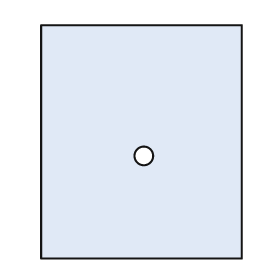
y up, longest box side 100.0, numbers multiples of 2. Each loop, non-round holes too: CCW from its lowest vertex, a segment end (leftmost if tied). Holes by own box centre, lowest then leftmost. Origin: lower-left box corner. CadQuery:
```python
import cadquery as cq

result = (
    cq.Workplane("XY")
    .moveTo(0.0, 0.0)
    .lineTo(86.0, 0.0)
    .lineTo(86.0, 100.0)
    .lineTo(0.0, 100.0)
    .close()
    .moveTo(44.0, 44.0)
    .circle(4.0)
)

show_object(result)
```